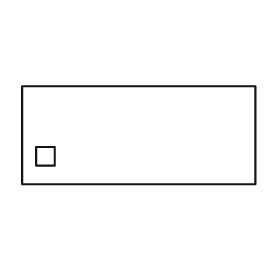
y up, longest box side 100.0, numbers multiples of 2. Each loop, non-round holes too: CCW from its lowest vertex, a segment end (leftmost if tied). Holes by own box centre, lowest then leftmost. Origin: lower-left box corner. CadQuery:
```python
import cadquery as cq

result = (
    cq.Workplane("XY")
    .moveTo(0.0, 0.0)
    .lineTo(100.0, 0.0)
    .lineTo(100.0, 42.0)
    .lineTo(0.0, 42.0)
    .close()
    .moveTo(6.0, 8.0)
    .lineTo(14.0, 8.0)
    .lineTo(14.0, 16.0)
    .lineTo(6.0, 16.0)
    .close()
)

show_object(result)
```